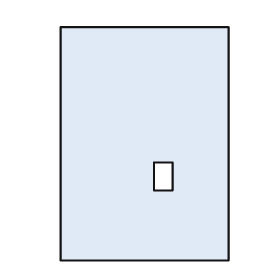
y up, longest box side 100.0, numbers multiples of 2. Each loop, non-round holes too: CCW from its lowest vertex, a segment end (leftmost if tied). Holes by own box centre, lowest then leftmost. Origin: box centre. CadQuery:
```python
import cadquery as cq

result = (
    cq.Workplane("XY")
    .moveTo(-36.0, -50.0)
    .lineTo(36.0, -50.0)
    .lineTo(36.0, 50.0)
    .lineTo(-36.0, 50.0)
    .close()
    .moveTo(4.0, -20.0)
    .lineTo(12.0, -20.0)
    .lineTo(12.0, -8.0)
    .lineTo(4.0, -8.0)
    .close()
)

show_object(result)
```